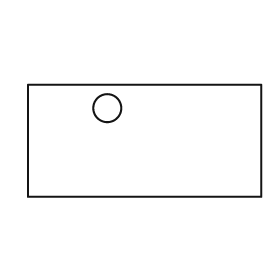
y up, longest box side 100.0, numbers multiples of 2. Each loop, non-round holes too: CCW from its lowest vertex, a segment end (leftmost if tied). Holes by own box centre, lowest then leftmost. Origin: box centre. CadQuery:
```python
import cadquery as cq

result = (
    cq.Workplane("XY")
    .moveTo(-50.0, -24.0)
    .lineTo(50.0, -24.0)
    .lineTo(50.0, 24.0)
    .lineTo(-50.0, 24.0)
    .close()
    .moveTo(-16.0, 14.0)
    .circle(6.0)
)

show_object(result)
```